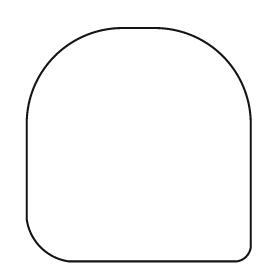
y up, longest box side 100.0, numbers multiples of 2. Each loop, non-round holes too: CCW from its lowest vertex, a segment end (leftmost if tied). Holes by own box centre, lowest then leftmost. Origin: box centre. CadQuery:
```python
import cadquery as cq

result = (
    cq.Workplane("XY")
    .moveTo(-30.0, -50.0)
    .lineTo(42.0, -50.0)
    .threePointArc((46.0, -48.0), (48.0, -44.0))
    .lineTo(48.0, 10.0)
    .threePointArc((36.0, 38.0), (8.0, 50.0))
    .lineTo(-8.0, 50.0)
    .threePointArc((-36.0, 38.0), (-48.0, 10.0))
    .lineTo(-48.0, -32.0)
    .threePointArc((-42.0, -44.0), (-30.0, -50.0))
    .close()
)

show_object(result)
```